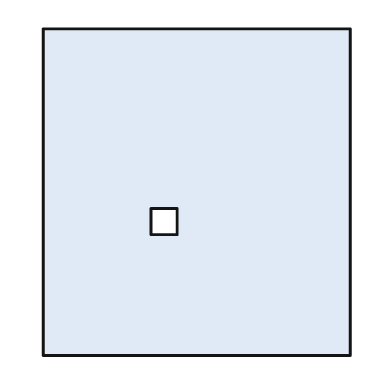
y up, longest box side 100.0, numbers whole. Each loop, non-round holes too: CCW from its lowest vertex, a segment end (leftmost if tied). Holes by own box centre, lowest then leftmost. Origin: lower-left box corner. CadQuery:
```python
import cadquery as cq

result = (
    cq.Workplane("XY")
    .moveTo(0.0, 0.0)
    .lineTo(94.0, 0.0)
    .lineTo(94.0, 100.0)
    .lineTo(0.0, 100.0)
    .close()
    .moveTo(33.0, 37.0)
    .lineTo(41.0, 37.0)
    .lineTo(41.0, 45.0)
    .lineTo(33.0, 45.0)
    .close()
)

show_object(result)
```